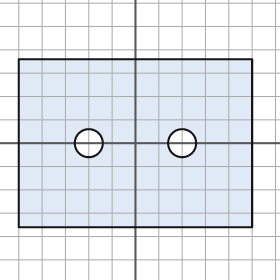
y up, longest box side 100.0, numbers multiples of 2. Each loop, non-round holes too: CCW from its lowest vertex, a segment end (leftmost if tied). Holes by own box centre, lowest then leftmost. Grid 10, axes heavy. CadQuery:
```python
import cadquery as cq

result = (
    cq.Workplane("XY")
    .moveTo(-50.0, -36.0)
    .lineTo(50.0, -36.0)
    .lineTo(50.0, 36.0)
    .lineTo(-50.0, 36.0)
    .close()
    .moveTo(-20.0, 0.0)
    .circle(6.0)
    .moveTo(20.0, 0.0)
    .circle(6.0)
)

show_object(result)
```